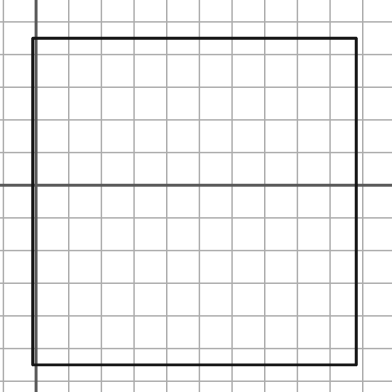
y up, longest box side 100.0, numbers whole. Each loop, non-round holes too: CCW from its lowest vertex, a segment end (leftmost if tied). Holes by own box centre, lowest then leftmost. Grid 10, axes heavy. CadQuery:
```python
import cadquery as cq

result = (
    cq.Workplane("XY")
    .moveTo(-1.0, -55.0)
    .lineTo(98.0, -55.0)
    .lineTo(98.0, 45.0)
    .lineTo(-1.0, 45.0)
    .close()
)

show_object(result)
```